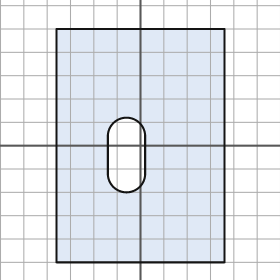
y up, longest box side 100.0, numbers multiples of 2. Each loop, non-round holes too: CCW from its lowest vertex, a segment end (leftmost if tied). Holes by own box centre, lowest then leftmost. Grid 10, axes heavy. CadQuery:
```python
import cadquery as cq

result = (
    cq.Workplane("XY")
    .moveTo(-36.0, -50.0)
    .lineTo(36.0, -50.0)
    .lineTo(36.0, 50.0)
    .lineTo(-36.0, 50.0)
    .close()
    .moveTo(-14.0, -12.0)
    .threePointArc((-6.0, -20.0), (2.0, -12.0))
    .lineTo(2.0, 4.0)
    .threePointArc((-6.0, 12.0), (-14.0, 4.0))
    .close()
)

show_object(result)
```